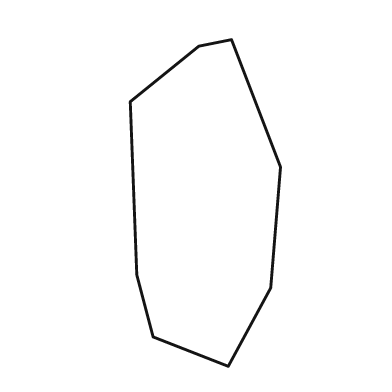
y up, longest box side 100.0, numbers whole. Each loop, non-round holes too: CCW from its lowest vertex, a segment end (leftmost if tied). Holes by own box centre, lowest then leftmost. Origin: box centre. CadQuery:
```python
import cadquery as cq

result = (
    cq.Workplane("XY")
    .moveTo(7.0, -50.0)
    .lineTo(20.0, -26.0)
    .lineTo(23.0, 11.0)
    .lineTo(8.0, 50.0)
    .lineTo(-2.0, 48.0)
    .lineTo(-23.0, 31.0)
    .lineTo(-21.0, -22.0)
    .lineTo(-16.0, -41.0)
    .close()
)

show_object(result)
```